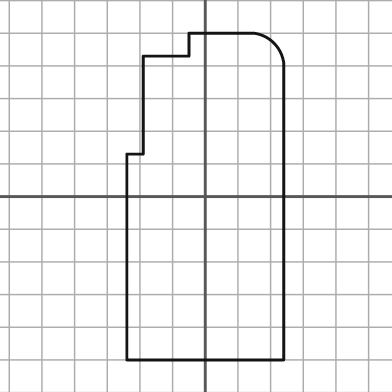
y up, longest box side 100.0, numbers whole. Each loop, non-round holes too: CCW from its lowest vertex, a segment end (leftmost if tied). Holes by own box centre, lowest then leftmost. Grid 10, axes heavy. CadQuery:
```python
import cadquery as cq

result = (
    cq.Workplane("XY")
    .moveTo(-24.0, -50.0)
    .lineTo(24.0, -50.0)
    .lineTo(24.0, 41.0)
    .threePointArc((21.0, 47.0), (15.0, 50.0))
    .lineTo(-5.0, 50.0)
    .lineTo(-5.0, 43.0)
    .lineTo(-19.0, 43.0)
    .lineTo(-19.0, 13.0)
    .lineTo(-24.0, 13.0)
    .close()
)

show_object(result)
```